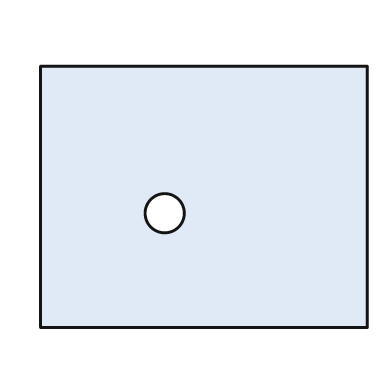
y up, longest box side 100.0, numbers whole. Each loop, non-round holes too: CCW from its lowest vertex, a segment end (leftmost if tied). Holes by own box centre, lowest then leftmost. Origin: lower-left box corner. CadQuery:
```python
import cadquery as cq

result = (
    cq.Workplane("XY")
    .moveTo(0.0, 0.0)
    .lineTo(100.0, 0.0)
    .lineTo(100.0, 80.0)
    .lineTo(0.0, 80.0)
    .close()
    .moveTo(38.0, 35.0)
    .circle(6.0)
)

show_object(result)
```